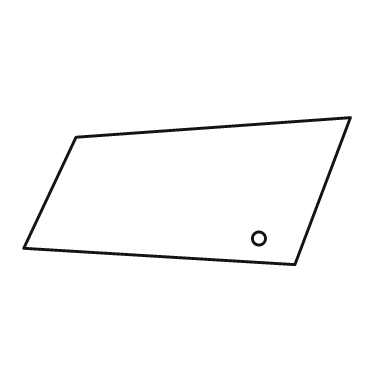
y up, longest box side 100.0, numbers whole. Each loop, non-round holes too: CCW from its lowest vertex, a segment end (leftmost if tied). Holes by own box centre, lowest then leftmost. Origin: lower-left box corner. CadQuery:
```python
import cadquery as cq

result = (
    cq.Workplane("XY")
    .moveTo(83.0, 0.0)
    .lineTo(100.0, 45.0)
    .lineTo(16.0, 39.0)
    .lineTo(0.0, 5.0)
    .close()
    .moveTo(72.0, 8.0)
    .circle(2.0)
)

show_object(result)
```